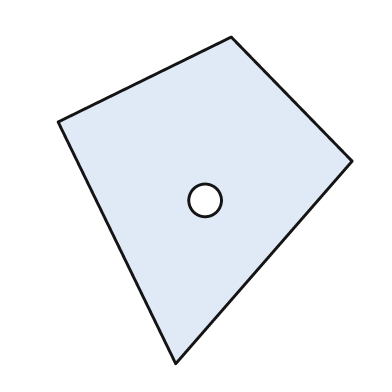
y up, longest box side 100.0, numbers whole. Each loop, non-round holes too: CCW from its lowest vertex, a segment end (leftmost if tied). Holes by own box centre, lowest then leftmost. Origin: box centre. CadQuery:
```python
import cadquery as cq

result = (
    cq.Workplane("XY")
    .moveTo(-9.0, -50.0)
    .lineTo(45.0, 12.0)
    .lineTo(8.0, 50.0)
    .lineTo(-45.0, 24.0)
    .close()
    .moveTo(0.0, 0.0)
    .circle(5.0)
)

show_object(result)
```